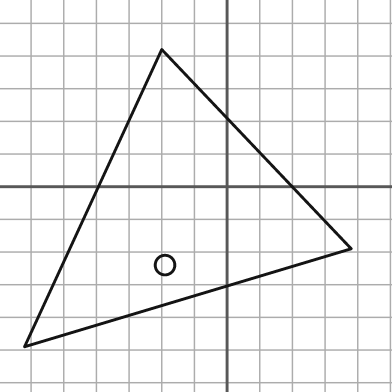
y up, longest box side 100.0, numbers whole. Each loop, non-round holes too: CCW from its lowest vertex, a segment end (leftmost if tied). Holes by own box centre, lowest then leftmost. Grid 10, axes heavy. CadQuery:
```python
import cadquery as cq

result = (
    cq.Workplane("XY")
    .moveTo(-62.0, -49.0)
    .lineTo(38.0, -19.0)
    .lineTo(-20.0, 42.0)
    .close()
    .moveTo(-19.0, -24.0)
    .circle(3.0)
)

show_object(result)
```